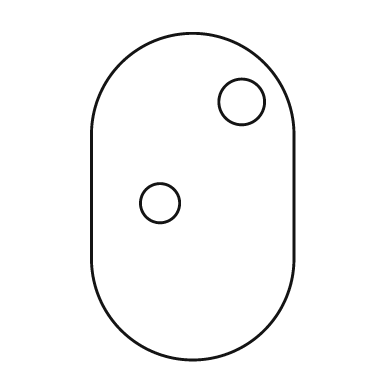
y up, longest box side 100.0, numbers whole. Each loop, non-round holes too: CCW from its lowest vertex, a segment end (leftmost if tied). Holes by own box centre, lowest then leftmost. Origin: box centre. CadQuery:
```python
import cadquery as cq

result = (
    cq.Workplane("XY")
    .moveTo(-31.0, -19.0)
    .threePointArc((0.0, -50.0), (31.0, -19.0))
    .lineTo(31.0, 19.0)
    .threePointArc((0.0, 50.0), (-31.0, 19.0))
    .close()
    .moveTo(-10.0, -2.0)
    .circle(6.0)
    .moveTo(15.0, 29.0)
    .circle(7.0)
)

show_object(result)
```